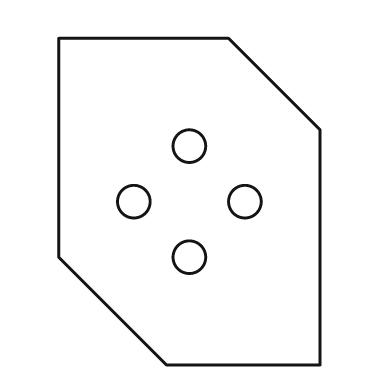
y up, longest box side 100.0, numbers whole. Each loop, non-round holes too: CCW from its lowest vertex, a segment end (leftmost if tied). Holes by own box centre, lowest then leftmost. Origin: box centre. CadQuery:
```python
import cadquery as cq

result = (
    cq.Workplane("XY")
    .moveTo(-7.0, -50.0)
    .lineTo(40.0, -50.0)
    .lineTo(40.0, 22.0)
    .lineTo(12.0, 50.0)
    .lineTo(-40.0, 50.0)
    .lineTo(-40.0, -17.0)
    .close()
    .moveTo(0.0, -17.0)
    .circle(5.0)
    .moveTo(-17.0, 0.0)
    .circle(5.0)
    .moveTo(17.0, 0.0)
    .circle(5.0)
    .moveTo(0.0, 17.0)
    .circle(5.0)
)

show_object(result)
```